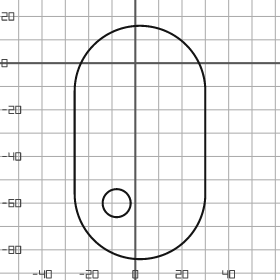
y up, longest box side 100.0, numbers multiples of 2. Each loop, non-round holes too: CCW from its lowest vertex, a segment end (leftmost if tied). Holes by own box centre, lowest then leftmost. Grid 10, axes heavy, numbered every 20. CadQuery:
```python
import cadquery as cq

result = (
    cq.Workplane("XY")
    .moveTo(-26.0, -56.0)
    .threePointArc((2.0, -84.0), (30.0, -56.0))
    .lineTo(30.0, -12.0)
    .threePointArc((2.0, 16.0), (-26.0, -12.0))
    .close()
    .moveTo(-8.0, -60.0)
    .circle(6.0)
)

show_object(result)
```